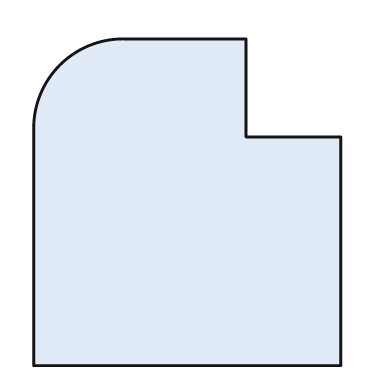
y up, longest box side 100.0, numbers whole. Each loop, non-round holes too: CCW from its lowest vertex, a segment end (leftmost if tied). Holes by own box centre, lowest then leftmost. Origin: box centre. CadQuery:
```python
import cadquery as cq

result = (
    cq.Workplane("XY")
    .moveTo(-47.0, -50.0)
    .lineTo(47.0, -50.0)
    .lineTo(47.0, 20.0)
    .lineTo(18.0, 20.0)
    .lineTo(18.0, 50.0)
    .lineTo(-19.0, 50.0)
    .threePointArc((-39.0, 42.0), (-47.0, 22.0))
    .close()
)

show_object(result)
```